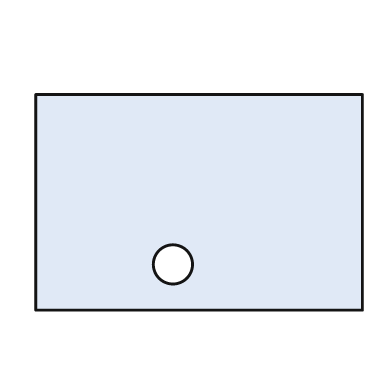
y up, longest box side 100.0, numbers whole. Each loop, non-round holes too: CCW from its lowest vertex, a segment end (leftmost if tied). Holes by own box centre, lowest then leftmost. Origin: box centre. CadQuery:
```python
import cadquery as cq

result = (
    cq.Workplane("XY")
    .moveTo(-50.0, -33.0)
    .lineTo(50.0, -33.0)
    .lineTo(50.0, 33.0)
    .lineTo(-50.0, 33.0)
    .close()
    .moveTo(-8.0, -19.0)
    .circle(6.0)
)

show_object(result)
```